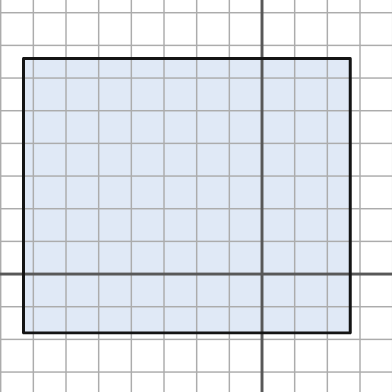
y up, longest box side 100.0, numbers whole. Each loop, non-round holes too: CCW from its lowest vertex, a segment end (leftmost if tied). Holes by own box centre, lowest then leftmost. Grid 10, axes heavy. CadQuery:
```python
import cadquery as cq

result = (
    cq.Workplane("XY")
    .moveTo(-73.0, -18.0)
    .lineTo(27.0, -18.0)
    .lineTo(27.0, 66.0)
    .lineTo(-73.0, 66.0)
    .close()
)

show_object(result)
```